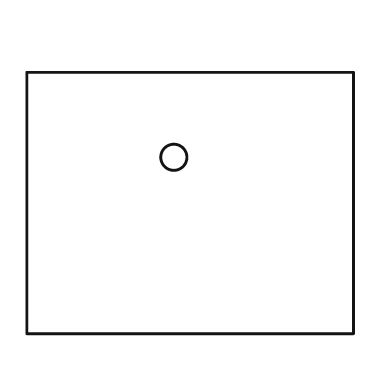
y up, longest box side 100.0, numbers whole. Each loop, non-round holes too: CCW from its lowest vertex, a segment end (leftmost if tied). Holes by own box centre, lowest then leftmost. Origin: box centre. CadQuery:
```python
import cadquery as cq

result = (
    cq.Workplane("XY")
    .moveTo(-50.0, -40.0)
    .lineTo(50.0, -40.0)
    .lineTo(50.0, 40.0)
    .lineTo(-50.0, 40.0)
    .close()
    .moveTo(-5.0, 14.0)
    .circle(4.0)
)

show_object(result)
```